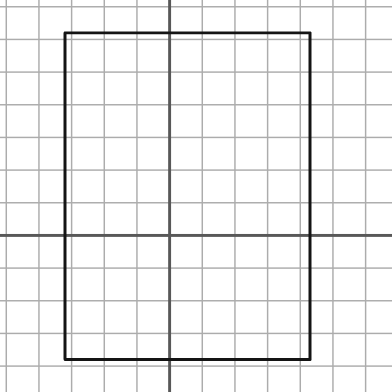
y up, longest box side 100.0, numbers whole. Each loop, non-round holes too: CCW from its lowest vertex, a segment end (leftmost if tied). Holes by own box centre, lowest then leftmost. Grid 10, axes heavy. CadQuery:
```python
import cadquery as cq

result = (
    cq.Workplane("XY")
    .moveTo(-32.0, -38.0)
    .lineTo(43.0, -38.0)
    .lineTo(43.0, 62.0)
    .lineTo(-32.0, 62.0)
    .close()
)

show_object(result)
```